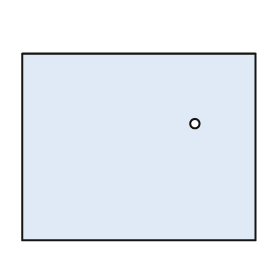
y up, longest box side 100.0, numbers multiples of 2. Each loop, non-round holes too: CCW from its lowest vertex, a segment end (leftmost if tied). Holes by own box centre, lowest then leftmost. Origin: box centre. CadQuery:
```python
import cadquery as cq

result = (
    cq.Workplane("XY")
    .moveTo(-50.0, -40.0)
    .lineTo(50.0, -40.0)
    .lineTo(50.0, 40.0)
    .lineTo(-50.0, 40.0)
    .close()
    .moveTo(24.0, 10.0)
    .circle(2.0)
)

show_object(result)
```